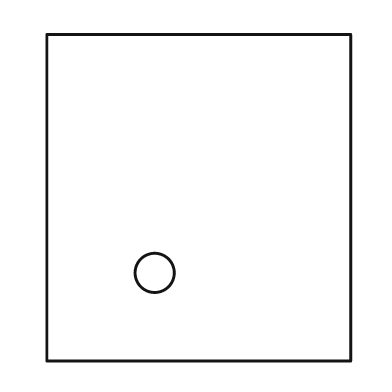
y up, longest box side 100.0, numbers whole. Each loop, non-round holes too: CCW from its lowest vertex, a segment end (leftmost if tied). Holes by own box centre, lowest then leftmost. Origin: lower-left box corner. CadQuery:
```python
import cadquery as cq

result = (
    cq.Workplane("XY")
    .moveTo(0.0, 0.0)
    .lineTo(93.0, 0.0)
    .lineTo(93.0, 100.0)
    .lineTo(0.0, 100.0)
    .close()
    .moveTo(33.0, 27.0)
    .circle(6.0)
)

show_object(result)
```